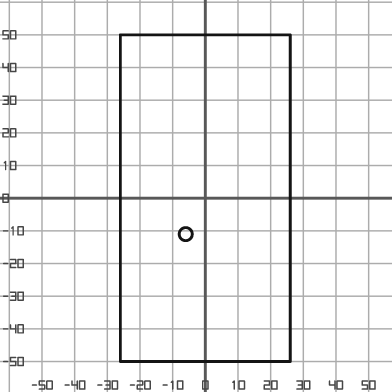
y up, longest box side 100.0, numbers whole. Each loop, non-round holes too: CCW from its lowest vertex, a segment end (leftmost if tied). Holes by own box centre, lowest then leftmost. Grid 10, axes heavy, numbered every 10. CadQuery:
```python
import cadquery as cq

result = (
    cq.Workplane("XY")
    .moveTo(-26.0, -50.0)
    .lineTo(26.0, -50.0)
    .lineTo(26.0, 50.0)
    .lineTo(-26.0, 50.0)
    .close()
    .moveTo(-6.0, -11.0)
    .circle(2.0)
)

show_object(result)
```